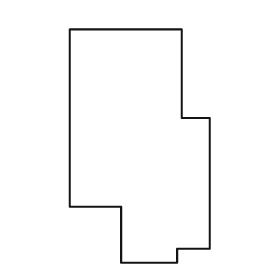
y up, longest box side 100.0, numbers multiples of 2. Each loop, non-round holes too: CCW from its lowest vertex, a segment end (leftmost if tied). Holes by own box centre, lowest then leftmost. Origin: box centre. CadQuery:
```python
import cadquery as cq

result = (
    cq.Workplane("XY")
    .moveTo(-8.0, -50.0)
    .lineTo(16.0, -50.0)
    .lineTo(16.0, -44.0)
    .lineTo(30.0, -44.0)
    .lineTo(30.0, 12.0)
    .lineTo(18.0, 12.0)
    .lineTo(18.0, 50.0)
    .lineTo(-30.0, 50.0)
    .lineTo(-30.0, -26.0)
    .lineTo(-8.0, -26.0)
    .close()
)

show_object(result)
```